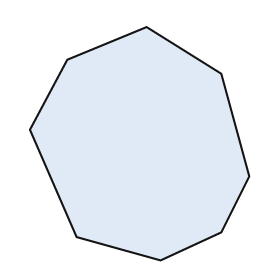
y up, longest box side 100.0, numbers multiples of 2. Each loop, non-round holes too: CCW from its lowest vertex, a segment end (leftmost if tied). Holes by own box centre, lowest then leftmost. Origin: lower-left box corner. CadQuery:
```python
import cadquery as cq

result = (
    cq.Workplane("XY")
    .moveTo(56.0, 0.0)
    .lineTo(82.0, 12.0)
    .lineTo(94.0, 36.0)
    .lineTo(82.0, 80.0)
    .lineTo(50.0, 100.0)
    .lineTo(16.0, 86.0)
    .lineTo(0.0, 56.0)
    .lineTo(20.0, 10.0)
    .close()
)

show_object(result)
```